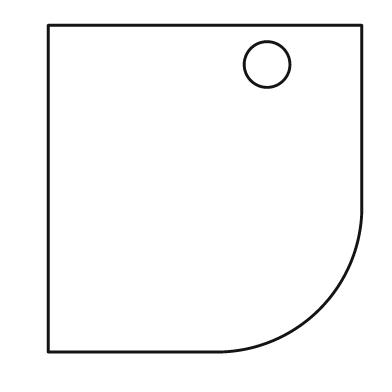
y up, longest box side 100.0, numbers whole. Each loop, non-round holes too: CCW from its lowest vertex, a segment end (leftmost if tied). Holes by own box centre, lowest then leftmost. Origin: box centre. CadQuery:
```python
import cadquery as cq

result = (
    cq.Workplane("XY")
    .moveTo(-48.0, -50.0)
    .lineTo(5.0, -50.0)
    .threePointArc((35.0, -37.0), (48.0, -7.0))
    .lineTo(48.0, 50.0)
    .lineTo(-48.0, 50.0)
    .close()
    .moveTo(19.0, 38.0)
    .circle(7.0)
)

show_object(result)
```